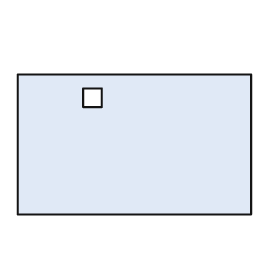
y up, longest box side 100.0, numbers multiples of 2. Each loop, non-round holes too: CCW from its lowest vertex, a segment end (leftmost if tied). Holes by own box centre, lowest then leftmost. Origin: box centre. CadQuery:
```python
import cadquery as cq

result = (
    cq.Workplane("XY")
    .moveTo(-50.0, -30.0)
    .lineTo(50.0, -30.0)
    .lineTo(50.0, 30.0)
    .lineTo(-50.0, 30.0)
    .close()
    .moveTo(-22.0, 16.0)
    .lineTo(-14.0, 16.0)
    .lineTo(-14.0, 24.0)
    .lineTo(-22.0, 24.0)
    .close()
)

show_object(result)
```